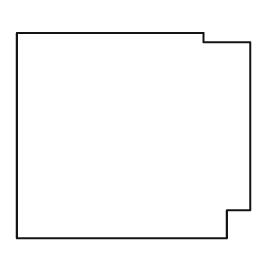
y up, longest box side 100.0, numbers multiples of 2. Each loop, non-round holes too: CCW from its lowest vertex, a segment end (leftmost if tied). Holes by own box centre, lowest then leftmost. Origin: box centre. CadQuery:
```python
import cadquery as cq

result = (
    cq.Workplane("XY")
    .moveTo(-50.0, -44.0)
    .lineTo(40.0, -44.0)
    .lineTo(40.0, -32.0)
    .lineTo(50.0, -32.0)
    .lineTo(50.0, 40.0)
    .lineTo(30.0, 40.0)
    .lineTo(30.0, 44.0)
    .lineTo(-50.0, 44.0)
    .close()
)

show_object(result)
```